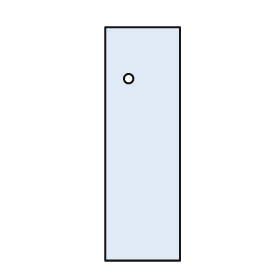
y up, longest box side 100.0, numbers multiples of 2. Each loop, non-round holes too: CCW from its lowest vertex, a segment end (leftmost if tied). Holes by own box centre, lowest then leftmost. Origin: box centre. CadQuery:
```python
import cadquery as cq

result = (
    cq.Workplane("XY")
    .moveTo(-16.0, -50.0)
    .lineTo(16.0, -50.0)
    .lineTo(16.0, 50.0)
    .lineTo(-16.0, 50.0)
    .close()
    .moveTo(-6.0, 28.0)
    .circle(2.0)
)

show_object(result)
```